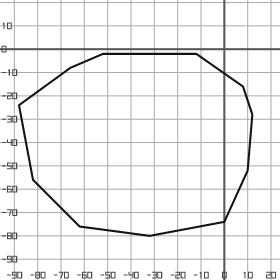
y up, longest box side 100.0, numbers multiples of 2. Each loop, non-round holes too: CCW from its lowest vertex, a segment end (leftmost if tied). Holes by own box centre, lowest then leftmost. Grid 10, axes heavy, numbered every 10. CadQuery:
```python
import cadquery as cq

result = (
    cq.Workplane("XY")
    .moveTo(-32.0, -80.0)
    .lineTo(0.0, -74.0)
    .lineTo(10.0, -52.0)
    .lineTo(12.0, -28.0)
    .lineTo(8.0, -16.0)
    .lineTo(-12.0, -2.0)
    .lineTo(-52.0, -2.0)
    .lineTo(-66.0, -8.0)
    .lineTo(-88.0, -24.0)
    .lineTo(-82.0, -56.0)
    .lineTo(-62.0, -76.0)
    .close()
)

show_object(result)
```